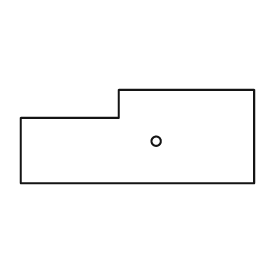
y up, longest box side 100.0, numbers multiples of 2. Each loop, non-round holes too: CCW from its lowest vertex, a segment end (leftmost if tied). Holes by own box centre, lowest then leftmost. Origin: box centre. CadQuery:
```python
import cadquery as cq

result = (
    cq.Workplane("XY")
    .moveTo(-50.0, -20.0)
    .lineTo(50.0, -20.0)
    .lineTo(50.0, 20.0)
    .lineTo(-8.0, 20.0)
    .lineTo(-8.0, 8.0)
    .lineTo(-50.0, 8.0)
    .close()
    .moveTo(8.0, -2.0)
    .circle(2.0)
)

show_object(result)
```